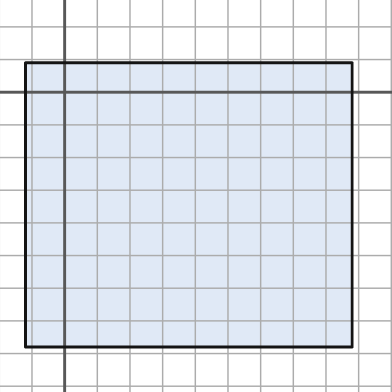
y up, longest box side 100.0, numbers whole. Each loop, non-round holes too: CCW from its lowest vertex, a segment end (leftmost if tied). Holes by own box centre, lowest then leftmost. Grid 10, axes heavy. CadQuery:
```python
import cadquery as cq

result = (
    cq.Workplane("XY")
    .moveTo(-12.0, -78.0)
    .lineTo(88.0, -78.0)
    .lineTo(88.0, 9.0)
    .lineTo(-12.0, 9.0)
    .close()
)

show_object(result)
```